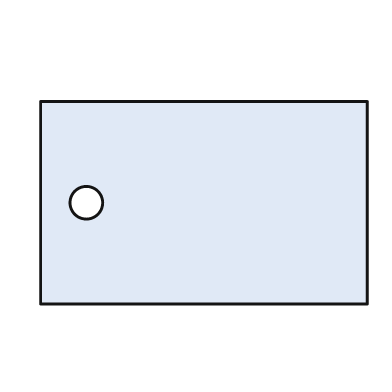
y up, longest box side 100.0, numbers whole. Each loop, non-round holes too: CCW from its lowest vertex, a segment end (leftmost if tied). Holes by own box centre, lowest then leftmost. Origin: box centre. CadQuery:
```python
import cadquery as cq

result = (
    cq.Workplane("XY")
    .moveTo(-50.0, -31.0)
    .lineTo(50.0, -31.0)
    .lineTo(50.0, 31.0)
    .lineTo(-50.0, 31.0)
    .close()
    .moveTo(-36.0, 0.0)
    .circle(5.0)
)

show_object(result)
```